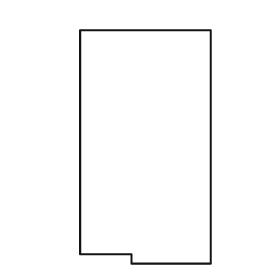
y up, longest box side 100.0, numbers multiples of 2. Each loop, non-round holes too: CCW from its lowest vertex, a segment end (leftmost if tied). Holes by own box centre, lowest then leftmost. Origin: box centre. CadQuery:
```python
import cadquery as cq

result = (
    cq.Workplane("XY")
    .moveTo(-6.0, -50.0)
    .lineTo(28.0, -50.0)
    .lineTo(28.0, 50.0)
    .lineTo(-28.0, 50.0)
    .lineTo(-28.0, -46.0)
    .lineTo(-6.0, -46.0)
    .close()
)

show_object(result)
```